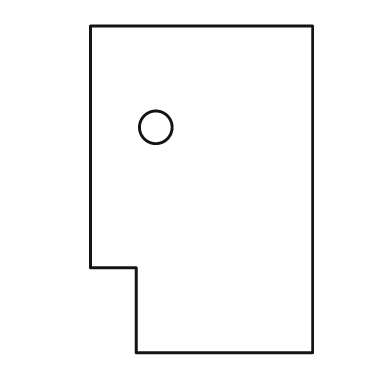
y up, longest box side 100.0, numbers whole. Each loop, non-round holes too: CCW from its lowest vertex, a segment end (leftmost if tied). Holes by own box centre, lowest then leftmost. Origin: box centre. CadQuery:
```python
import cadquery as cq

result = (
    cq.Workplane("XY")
    .moveTo(-20.0, -50.0)
    .lineTo(34.0, -50.0)
    .lineTo(34.0, 50.0)
    .lineTo(-34.0, 50.0)
    .lineTo(-34.0, -24.0)
    .lineTo(-20.0, -24.0)
    .close()
    .moveTo(-14.0, 19.0)
    .circle(5.0)
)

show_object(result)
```